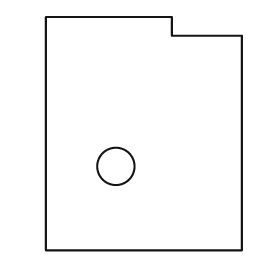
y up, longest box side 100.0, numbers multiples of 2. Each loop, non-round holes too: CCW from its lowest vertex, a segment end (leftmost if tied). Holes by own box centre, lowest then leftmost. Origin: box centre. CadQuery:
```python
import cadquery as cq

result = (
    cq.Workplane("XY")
    .moveTo(-42.0, -50.0)
    .lineTo(42.0, -50.0)
    .lineTo(42.0, 42.0)
    .lineTo(12.0, 42.0)
    .lineTo(12.0, 50.0)
    .lineTo(-42.0, 50.0)
    .close()
    .moveTo(-12.0, -14.0)
    .circle(8.0)
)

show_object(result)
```